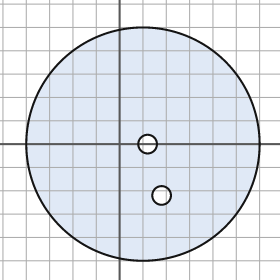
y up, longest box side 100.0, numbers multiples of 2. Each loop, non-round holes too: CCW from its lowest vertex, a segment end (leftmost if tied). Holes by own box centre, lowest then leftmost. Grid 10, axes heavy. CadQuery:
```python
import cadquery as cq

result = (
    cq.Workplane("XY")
    .moveTo(10.0, 0.0)
    .circle(50.0)
    .moveTo(18.0, -22.0)
    .circle(4.0)
    .moveTo(12.0, 0.0)
    .circle(4.0)
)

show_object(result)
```